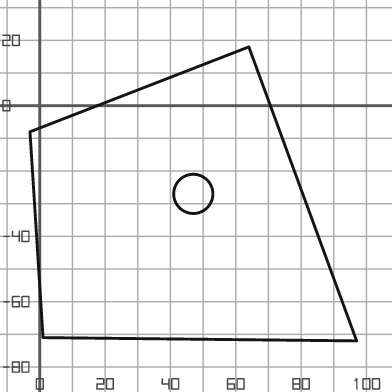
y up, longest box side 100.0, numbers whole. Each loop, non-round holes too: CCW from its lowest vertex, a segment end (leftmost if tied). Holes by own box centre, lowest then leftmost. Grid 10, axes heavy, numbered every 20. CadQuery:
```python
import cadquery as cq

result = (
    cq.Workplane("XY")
    .moveTo(97.0, -72.0)
    .lineTo(64.0, 18.0)
    .lineTo(-3.0, -8.0)
    .lineTo(1.0, -71.0)
    .close()
    .moveTo(47.0, -27.0)
    .circle(6.0)
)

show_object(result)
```